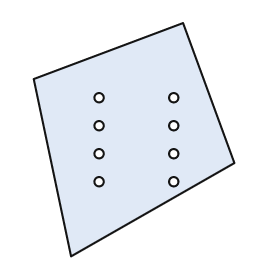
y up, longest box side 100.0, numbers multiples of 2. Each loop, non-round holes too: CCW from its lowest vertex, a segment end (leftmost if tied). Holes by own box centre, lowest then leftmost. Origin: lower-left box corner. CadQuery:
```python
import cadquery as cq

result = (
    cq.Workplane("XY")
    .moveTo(16.0, 0.0)
    .lineTo(86.0, 40.0)
    .lineTo(64.0, 100.0)
    .lineTo(0.0, 76.0)
    .close()
    .moveTo(28.0, 32.0)
    .circle(2.0)
    .moveTo(60.0, 32.0)
    .circle(2.0)
    .moveTo(28.0, 44.0)
    .circle(2.0)
    .moveTo(60.0, 44.0)
    .circle(2.0)
    .moveTo(28.0, 56.0)
    .circle(2.0)
    .moveTo(60.0, 56.0)
    .circle(2.0)
    .moveTo(28.0, 68.0)
    .circle(2.0)
    .moveTo(60.0, 68.0)
    .circle(2.0)
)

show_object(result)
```